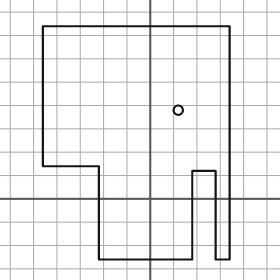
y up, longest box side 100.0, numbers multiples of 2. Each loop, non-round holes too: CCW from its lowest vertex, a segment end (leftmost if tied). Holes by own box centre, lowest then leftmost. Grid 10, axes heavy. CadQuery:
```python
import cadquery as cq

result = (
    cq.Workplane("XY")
    .moveTo(-22.0, -26.0)
    .lineTo(18.0, -26.0)
    .lineTo(18.0, 12.0)
    .lineTo(28.0, 12.0)
    .lineTo(28.0, -26.0)
    .lineTo(34.0, -26.0)
    .lineTo(34.0, 74.0)
    .lineTo(-46.0, 74.0)
    .lineTo(-46.0, 14.0)
    .lineTo(-22.0, 14.0)
    .close()
    .moveTo(12.0, 38.0)
    .circle(2.0)
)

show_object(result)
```